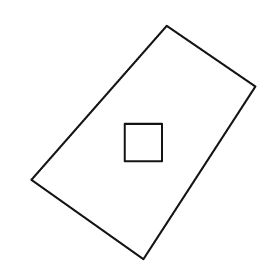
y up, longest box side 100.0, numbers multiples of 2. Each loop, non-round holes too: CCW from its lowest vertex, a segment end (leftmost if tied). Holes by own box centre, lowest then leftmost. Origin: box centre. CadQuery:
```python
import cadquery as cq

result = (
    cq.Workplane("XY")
    .moveTo(0.0, -50.0)
    .lineTo(48.0, 24.0)
    .lineTo(10.0, 50.0)
    .lineTo(-48.0, -16.0)
    .close()
    .moveTo(-8.0, -8.0)
    .lineTo(8.0, -8.0)
    .lineTo(8.0, 8.0)
    .lineTo(-8.0, 8.0)
    .close()
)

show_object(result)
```